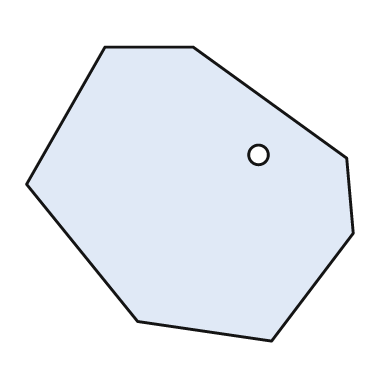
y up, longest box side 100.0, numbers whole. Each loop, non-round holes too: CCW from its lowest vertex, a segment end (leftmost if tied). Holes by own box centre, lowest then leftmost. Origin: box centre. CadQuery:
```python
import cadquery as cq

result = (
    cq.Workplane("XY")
    .moveTo(25.0, -45.0)
    .lineTo(50.0, -12.0)
    .lineTo(48.0, 11.0)
    .lineTo(1.0, 45.0)
    .lineTo(-26.0, 45.0)
    .lineTo(-50.0, 3.0)
    .lineTo(-16.0, -39.0)
    .close()
    .moveTo(21.0, 12.0)
    .circle(3.0)
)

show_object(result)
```